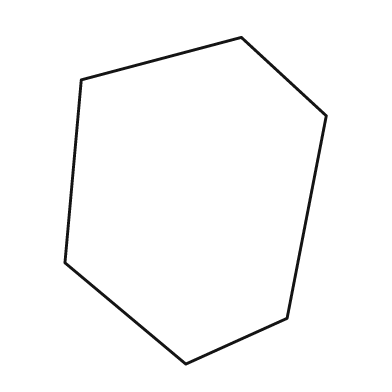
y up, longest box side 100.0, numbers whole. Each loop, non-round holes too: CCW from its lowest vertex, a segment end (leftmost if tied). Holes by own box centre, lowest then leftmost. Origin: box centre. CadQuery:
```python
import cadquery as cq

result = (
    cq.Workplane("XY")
    .moveTo(-3.0, -50.0)
    .lineTo(28.0, -36.0)
    .lineTo(40.0, 26.0)
    .lineTo(14.0, 50.0)
    .lineTo(-35.0, 37.0)
    .lineTo(-40.0, -19.0)
    .close()
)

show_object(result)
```